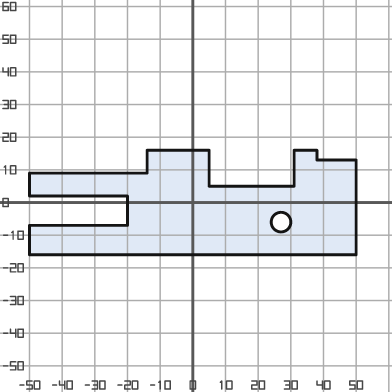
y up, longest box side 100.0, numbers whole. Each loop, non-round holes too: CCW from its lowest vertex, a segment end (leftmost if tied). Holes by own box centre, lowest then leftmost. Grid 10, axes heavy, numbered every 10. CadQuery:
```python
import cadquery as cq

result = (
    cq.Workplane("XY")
    .moveTo(-50.0, -16.0)
    .lineTo(50.0, -16.0)
    .lineTo(50.0, 13.0)
    .lineTo(38.0, 13.0)
    .lineTo(38.0, 16.0)
    .lineTo(31.0, 16.0)
    .lineTo(31.0, 5.0)
    .lineTo(5.0, 5.0)
    .lineTo(5.0, 16.0)
    .lineTo(-14.0, 16.0)
    .lineTo(-14.0, 9.0)
    .lineTo(-50.0, 9.0)
    .lineTo(-50.0, 2.0)
    .lineTo(-20.0, 2.0)
    .lineTo(-20.0, -7.0)
    .lineTo(-50.0, -7.0)
    .close()
    .moveTo(27.0, -6.0)
    .circle(3.0)
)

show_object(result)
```